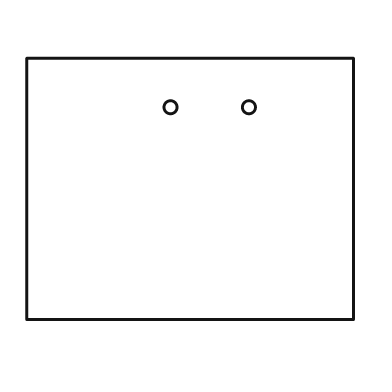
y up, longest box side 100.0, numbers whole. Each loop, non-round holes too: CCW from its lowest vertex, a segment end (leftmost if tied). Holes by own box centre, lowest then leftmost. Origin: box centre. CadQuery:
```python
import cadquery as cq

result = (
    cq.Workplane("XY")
    .moveTo(-50.0, -40.0)
    .lineTo(50.0, -40.0)
    .lineTo(50.0, 40.0)
    .lineTo(-50.0, 40.0)
    .close()
    .moveTo(-6.0, 25.0)
    .circle(2.0)
    .moveTo(18.0, 25.0)
    .circle(2.0)
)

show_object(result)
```